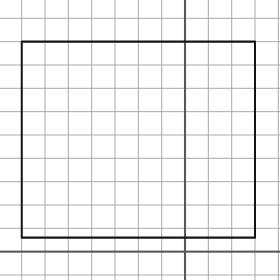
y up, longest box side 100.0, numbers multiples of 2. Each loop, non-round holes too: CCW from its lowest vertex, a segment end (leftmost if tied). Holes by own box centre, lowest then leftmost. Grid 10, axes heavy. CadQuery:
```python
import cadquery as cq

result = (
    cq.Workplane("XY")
    .moveTo(-70.0, 6.0)
    .lineTo(30.0, 6.0)
    .lineTo(30.0, 90.0)
    .lineTo(-70.0, 90.0)
    .close()
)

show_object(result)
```